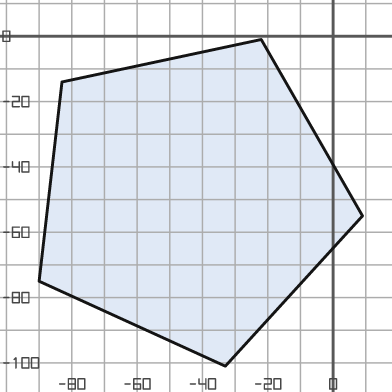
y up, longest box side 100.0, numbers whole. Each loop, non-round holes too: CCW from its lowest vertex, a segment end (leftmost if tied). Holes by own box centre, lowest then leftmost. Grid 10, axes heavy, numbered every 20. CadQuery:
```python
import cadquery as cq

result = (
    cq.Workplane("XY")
    .moveTo(-33.0, -101.0)
    .lineTo(9.0, -55.0)
    .lineTo(-22.0, -1.0)
    .lineTo(-83.0, -14.0)
    .lineTo(-90.0, -75.0)
    .close()
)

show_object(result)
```